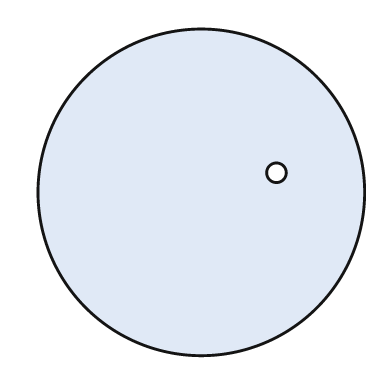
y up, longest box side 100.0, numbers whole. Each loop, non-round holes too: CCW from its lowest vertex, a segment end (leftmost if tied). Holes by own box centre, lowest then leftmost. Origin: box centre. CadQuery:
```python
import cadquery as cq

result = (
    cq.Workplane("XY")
    .moveTo(0.0, 0.0)
    .circle(50.0)
    .moveTo(23.0, 6.0)
    .circle(3.0)
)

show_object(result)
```